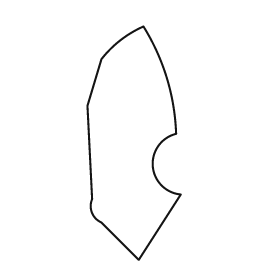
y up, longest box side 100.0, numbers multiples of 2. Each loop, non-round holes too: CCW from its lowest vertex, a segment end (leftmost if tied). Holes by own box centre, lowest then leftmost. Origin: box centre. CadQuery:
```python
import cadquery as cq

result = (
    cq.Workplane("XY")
    .moveTo(2.0, -50.0)
    .lineTo(20.0, -22.0)
    .threePointArc((8.0, -10.0), (18.0, 4.0))
    .threePointArc((14.0, 28.0), (4.0, 50.0))
    .threePointArc((-6.0, 44.0), (-14.0, 36.0))
    .lineTo(-20.0, 16.0)
    .lineTo(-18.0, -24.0)
    .threePointArc((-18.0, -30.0), (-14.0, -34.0))
    .close()
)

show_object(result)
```